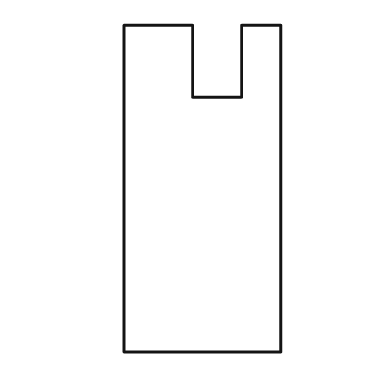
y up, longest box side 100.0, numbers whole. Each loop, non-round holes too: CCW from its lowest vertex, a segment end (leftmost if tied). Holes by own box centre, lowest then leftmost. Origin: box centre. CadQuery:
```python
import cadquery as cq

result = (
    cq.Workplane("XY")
    .moveTo(-24.0, -50.0)
    .lineTo(24.0, -50.0)
    .lineTo(24.0, 50.0)
    .lineTo(12.0, 50.0)
    .lineTo(12.0, 28.0)
    .lineTo(-3.0, 28.0)
    .lineTo(-3.0, 50.0)
    .lineTo(-24.0, 50.0)
    .close()
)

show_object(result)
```